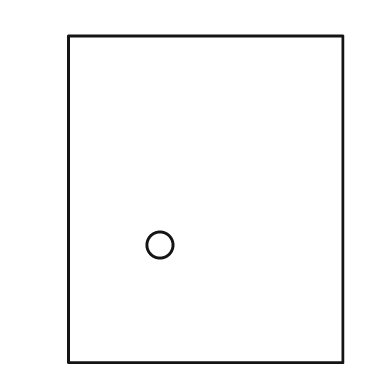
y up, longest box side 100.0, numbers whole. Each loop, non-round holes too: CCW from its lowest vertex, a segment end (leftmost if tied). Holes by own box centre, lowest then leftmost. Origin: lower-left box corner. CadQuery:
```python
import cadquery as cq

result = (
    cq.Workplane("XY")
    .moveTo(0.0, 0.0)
    .lineTo(84.0, 0.0)
    .lineTo(84.0, 100.0)
    .lineTo(0.0, 100.0)
    .close()
    .moveTo(28.0, 36.0)
    .circle(4.0)
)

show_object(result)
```